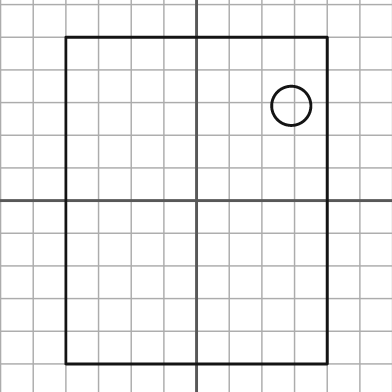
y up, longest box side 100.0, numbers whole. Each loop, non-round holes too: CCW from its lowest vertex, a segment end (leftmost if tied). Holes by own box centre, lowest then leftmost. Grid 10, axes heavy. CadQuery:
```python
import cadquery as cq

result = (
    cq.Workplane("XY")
    .moveTo(-40.0, -50.0)
    .lineTo(40.0, -50.0)
    .lineTo(40.0, 50.0)
    .lineTo(-40.0, 50.0)
    .close()
    .moveTo(29.0, 29.0)
    .circle(6.0)
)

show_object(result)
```